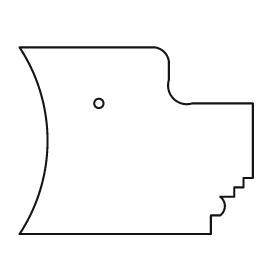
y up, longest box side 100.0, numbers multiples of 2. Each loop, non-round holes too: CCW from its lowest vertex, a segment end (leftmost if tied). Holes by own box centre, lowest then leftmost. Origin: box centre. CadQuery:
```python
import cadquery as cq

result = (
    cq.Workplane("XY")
    .moveTo(-50.0, -40.0)
    .lineTo(32.0, -40.0)
    .lineTo(32.0, -32.0)
    .lineTo(36.0, -32.0)
    .threePointArc((38.0, -28.0), (36.0, -24.0))
    .lineTo(42.0, -24.0)
    .lineTo(42.0, -20.0)
    .lineTo(46.0, -20.0)
    .lineTo(46.0, -16.0)
    .lineTo(50.0, -16.0)
    .lineTo(50.0, 16.0)
    .lineTo(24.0, 16.0)
    .threePointArc((16.0, 18.0), (14.0, 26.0))
    .lineTo(14.0, 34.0)
    .threePointArc((12.0, 38.0), (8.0, 40.0))
    .lineTo(-50.0, 40.0)
    .threePointArc((-38.0, 0.0), (-50.0, -40.0))
    .close()
    .moveTo(-16.0, 16.0)
    .circle(2.0)
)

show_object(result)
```